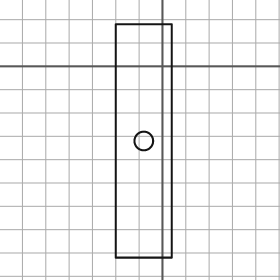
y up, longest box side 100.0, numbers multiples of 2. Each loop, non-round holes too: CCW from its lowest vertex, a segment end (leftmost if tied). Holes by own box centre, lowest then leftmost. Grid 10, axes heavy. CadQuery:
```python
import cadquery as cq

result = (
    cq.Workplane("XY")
    .moveTo(-20.0, -82.0)
    .lineTo(4.0, -82.0)
    .lineTo(4.0, 18.0)
    .lineTo(-20.0, 18.0)
    .close()
    .moveTo(-8.0, -32.0)
    .circle(4.0)
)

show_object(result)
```